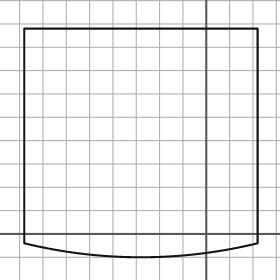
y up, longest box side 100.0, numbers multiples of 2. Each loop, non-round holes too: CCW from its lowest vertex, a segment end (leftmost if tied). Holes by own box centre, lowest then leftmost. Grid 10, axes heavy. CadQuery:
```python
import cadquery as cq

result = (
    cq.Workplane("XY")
    .moveTo(-78.0, -4.0)
    .threePointArc((-28.0, -10.0), (22.0, -4.0))
    .lineTo(22.0, 88.0)
    .lineTo(-78.0, 88.0)
    .close()
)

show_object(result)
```